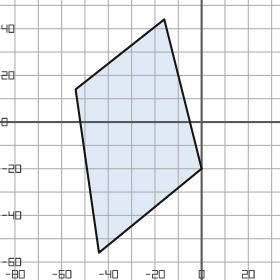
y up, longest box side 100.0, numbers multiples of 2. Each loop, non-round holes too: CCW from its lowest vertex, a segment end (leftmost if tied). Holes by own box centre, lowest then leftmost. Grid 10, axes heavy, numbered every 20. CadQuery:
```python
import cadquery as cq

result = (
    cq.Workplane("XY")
    .moveTo(-44.0, -56.0)
    .lineTo(0.0, -20.0)
    .lineTo(-16.0, 44.0)
    .lineTo(-54.0, 14.0)
    .close()
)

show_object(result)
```